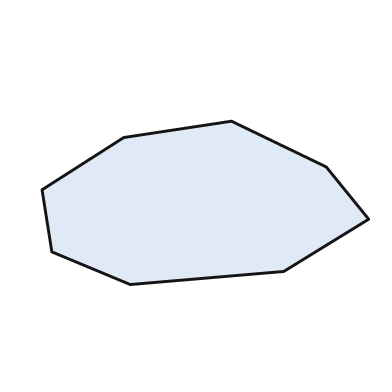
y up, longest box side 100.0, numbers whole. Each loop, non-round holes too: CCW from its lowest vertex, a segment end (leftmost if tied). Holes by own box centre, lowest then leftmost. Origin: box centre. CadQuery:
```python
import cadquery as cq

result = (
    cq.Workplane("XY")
    .moveTo(-23.0, -25.0)
    .lineTo(24.0, -21.0)
    .lineTo(50.0, -5.0)
    .lineTo(37.0, 11.0)
    .lineTo(8.0, 25.0)
    .lineTo(-25.0, 20.0)
    .lineTo(-50.0, 4.0)
    .lineTo(-47.0, -15.0)
    .close()
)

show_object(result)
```